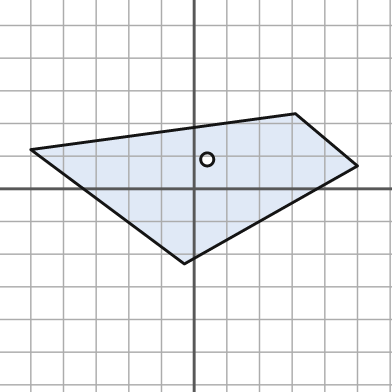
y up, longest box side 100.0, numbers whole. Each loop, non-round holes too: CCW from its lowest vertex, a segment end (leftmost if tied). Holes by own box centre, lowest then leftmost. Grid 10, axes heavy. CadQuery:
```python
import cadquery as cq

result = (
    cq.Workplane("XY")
    .moveTo(-3.0, -23.0)
    .lineTo(50.0, 7.0)
    .lineTo(31.0, 23.0)
    .lineTo(-50.0, 12.0)
    .close()
    .moveTo(4.0, 9.0)
    .circle(2.0)
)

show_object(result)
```